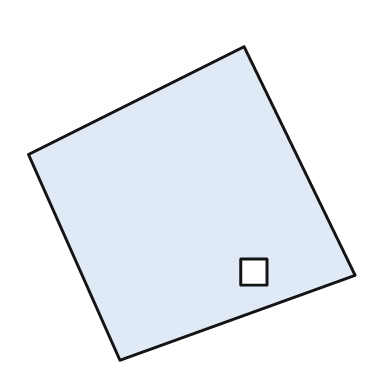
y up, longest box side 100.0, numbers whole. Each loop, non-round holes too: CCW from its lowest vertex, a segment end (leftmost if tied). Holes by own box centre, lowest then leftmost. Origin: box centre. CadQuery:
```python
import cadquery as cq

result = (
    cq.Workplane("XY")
    .moveTo(-22.0, -48.0)
    .lineTo(50.0, -22.0)
    .lineTo(16.0, 48.0)
    .lineTo(-50.0, 15.0)
    .close()
    .moveTo(15.0, -25.0)
    .lineTo(23.0, -25.0)
    .lineTo(23.0, -17.0)
    .lineTo(15.0, -17.0)
    .close()
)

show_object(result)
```